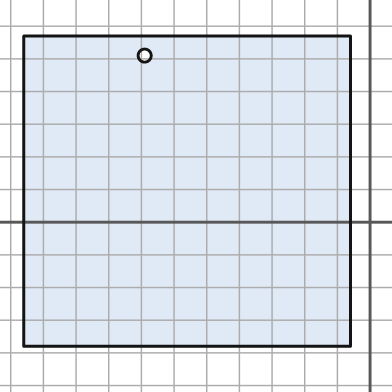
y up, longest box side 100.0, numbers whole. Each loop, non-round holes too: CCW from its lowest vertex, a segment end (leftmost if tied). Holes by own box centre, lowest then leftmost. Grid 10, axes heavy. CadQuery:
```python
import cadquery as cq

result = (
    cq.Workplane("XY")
    .moveTo(-106.0, -38.0)
    .lineTo(-6.0, -38.0)
    .lineTo(-6.0, 57.0)
    .lineTo(-106.0, 57.0)
    .close()
    .moveTo(-69.0, 51.0)
    .circle(2.0)
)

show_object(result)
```